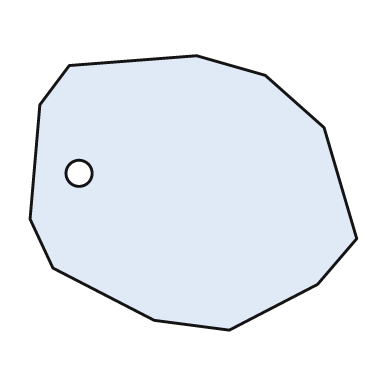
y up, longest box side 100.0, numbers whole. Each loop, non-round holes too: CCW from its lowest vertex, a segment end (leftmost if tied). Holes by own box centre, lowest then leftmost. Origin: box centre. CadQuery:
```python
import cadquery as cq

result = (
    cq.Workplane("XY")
    .moveTo(11.0, -42.0)
    .lineTo(38.0, -28.0)
    .lineTo(50.0, -14.0)
    .lineTo(40.0, 20.0)
    .lineTo(22.0, 36.0)
    .lineTo(1.0, 42.0)
    .lineTo(-38.0, 39.0)
    .lineTo(-47.0, 27.0)
    .lineTo(-50.0, -8.0)
    .lineTo(-43.0, -23.0)
    .lineTo(-12.0, -39.0)
    .close()
    .moveTo(-35.0, 6.0)
    .circle(4.0)
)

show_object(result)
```